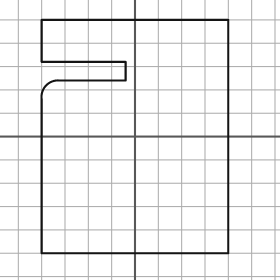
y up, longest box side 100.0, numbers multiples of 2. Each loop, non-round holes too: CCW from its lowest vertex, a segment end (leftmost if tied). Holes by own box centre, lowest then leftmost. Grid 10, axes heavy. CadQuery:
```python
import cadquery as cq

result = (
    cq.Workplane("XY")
    .moveTo(-40.0, -50.0)
    .lineTo(40.0, -50.0)
    .lineTo(40.0, 50.0)
    .lineTo(-40.0, 50.0)
    .lineTo(-40.0, 32.0)
    .lineTo(-4.0, 32.0)
    .lineTo(-4.0, 24.0)
    .lineTo(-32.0, 24.0)
    .threePointArc((-38.0, 22.0), (-40.0, 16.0))
    .close()
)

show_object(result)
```